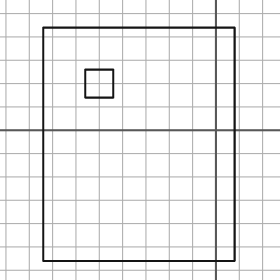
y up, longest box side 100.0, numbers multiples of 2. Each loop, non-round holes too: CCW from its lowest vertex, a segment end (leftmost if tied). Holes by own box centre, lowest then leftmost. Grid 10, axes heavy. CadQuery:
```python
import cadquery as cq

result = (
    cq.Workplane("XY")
    .moveTo(-74.0, -56.0)
    .lineTo(8.0, -56.0)
    .lineTo(8.0, 44.0)
    .lineTo(-74.0, 44.0)
    .close()
    .moveTo(-56.0, 14.0)
    .lineTo(-44.0, 14.0)
    .lineTo(-44.0, 26.0)
    .lineTo(-56.0, 26.0)
    .close()
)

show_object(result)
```